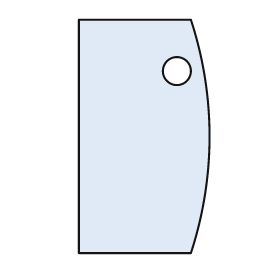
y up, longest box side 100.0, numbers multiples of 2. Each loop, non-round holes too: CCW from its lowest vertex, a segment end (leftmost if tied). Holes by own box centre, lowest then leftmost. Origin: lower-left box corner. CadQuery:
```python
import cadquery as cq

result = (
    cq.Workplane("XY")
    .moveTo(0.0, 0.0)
    .lineTo(48.0, 0.0)
    .threePointArc((56.0, 50.0), (48.0, 100.0))
    .lineTo(0.0, 100.0)
    .close()
    .moveTo(42.0, 78.0)
    .circle(6.0)
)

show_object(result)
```